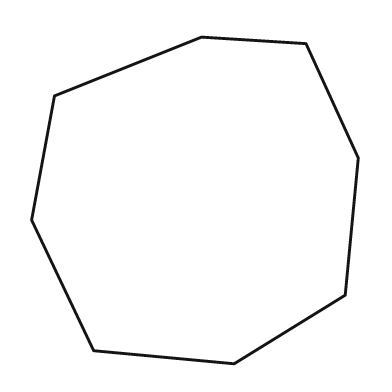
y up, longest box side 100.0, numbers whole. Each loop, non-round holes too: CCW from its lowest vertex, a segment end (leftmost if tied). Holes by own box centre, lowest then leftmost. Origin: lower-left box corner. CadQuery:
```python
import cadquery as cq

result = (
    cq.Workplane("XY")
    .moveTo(62.0, 0.0)
    .lineTo(96.0, 21.0)
    .lineTo(100.0, 63.0)
    .lineTo(84.0, 98.0)
    .lineTo(52.0, 100.0)
    .lineTo(7.0, 82.0)
    .lineTo(0.0, 44.0)
    .lineTo(19.0, 4.0)
    .close()
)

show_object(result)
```